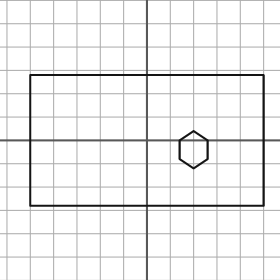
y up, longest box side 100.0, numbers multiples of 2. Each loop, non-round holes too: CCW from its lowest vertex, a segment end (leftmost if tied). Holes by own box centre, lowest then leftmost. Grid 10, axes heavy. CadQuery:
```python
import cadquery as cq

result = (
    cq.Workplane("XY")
    .moveTo(-50.0, -28.0)
    .lineTo(50.0, -28.0)
    .lineTo(50.0, 28.0)
    .lineTo(-50.0, 28.0)
    .close()
    .moveTo(20.0, -12.0)
    .lineTo(26.0, -8.0)
    .lineTo(26.0, 0.0)
    .lineTo(20.0, 4.0)
    .lineTo(14.0, 0.0)
    .lineTo(14.0, -8.0)
    .close()
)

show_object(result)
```